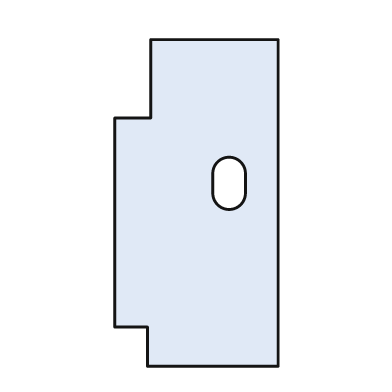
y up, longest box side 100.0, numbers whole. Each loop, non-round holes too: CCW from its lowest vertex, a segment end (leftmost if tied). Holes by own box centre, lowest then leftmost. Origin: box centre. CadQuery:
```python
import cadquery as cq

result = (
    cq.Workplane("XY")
    .moveTo(-15.0, -50.0)
    .lineTo(25.0, -50.0)
    .lineTo(25.0, 50.0)
    .lineTo(-14.0, 50.0)
    .lineTo(-14.0, 26.0)
    .lineTo(-25.0, 26.0)
    .lineTo(-25.0, -38.0)
    .lineTo(-15.0, -38.0)
    .close()
    .moveTo(5.0, 3.0)
    .threePointArc((10.0, -2.0), (15.0, 3.0))
    .lineTo(15.0, 9.0)
    .threePointArc((10.0, 14.0), (5.0, 9.0))
    .close()
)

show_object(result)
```